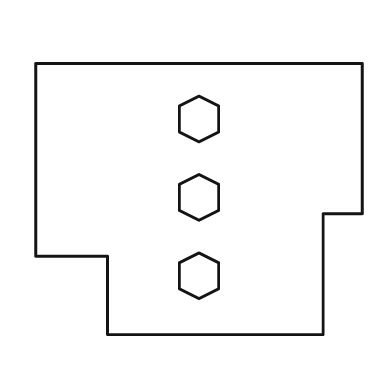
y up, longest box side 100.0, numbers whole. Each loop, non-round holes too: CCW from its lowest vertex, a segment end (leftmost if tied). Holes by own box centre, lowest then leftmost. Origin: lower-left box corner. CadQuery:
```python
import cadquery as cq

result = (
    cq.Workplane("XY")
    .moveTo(22.0, 0.0)
    .lineTo(88.0, 0.0)
    .lineTo(88.0, 37.0)
    .lineTo(100.0, 37.0)
    .lineTo(100.0, 83.0)
    .lineTo(0.0, 83.0)
    .lineTo(0.0, 24.0)
    .lineTo(22.0, 24.0)
    .close()
    .moveTo(50.0, 11.0)
    .lineTo(56.0, 14.0)
    .lineTo(56.0, 22.0)
    .lineTo(50.0, 25.0)
    .lineTo(44.0, 22.0)
    .lineTo(44.0, 14.0)
    .close()
    .moveTo(50.0, 35.0)
    .lineTo(56.0, 38.0)
    .lineTo(56.0, 46.0)
    .lineTo(50.0, 49.0)
    .lineTo(44.0, 46.0)
    .lineTo(44.0, 38.0)
    .close()
    .moveTo(50.0, 59.0)
    .lineTo(56.0, 62.0)
    .lineTo(56.0, 70.0)
    .lineTo(50.0, 73.0)
    .lineTo(44.0, 70.0)
    .lineTo(44.0, 62.0)
    .close()
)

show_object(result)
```